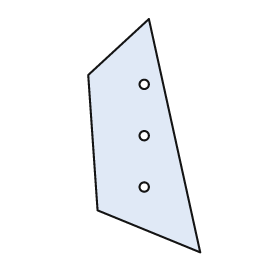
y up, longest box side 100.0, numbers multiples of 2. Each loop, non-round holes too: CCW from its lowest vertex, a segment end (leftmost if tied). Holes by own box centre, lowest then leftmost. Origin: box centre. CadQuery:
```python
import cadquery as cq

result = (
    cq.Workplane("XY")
    .moveTo(24.0, -50.0)
    .lineTo(2.0, 50.0)
    .lineTo(-24.0, 26.0)
    .lineTo(-20.0, -32.0)
    .close()
    .moveTo(0.0, -22.0)
    .circle(2.0)
    .moveTo(0.0, 0.0)
    .circle(2.0)
    .moveTo(0.0, 22.0)
    .circle(2.0)
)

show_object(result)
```